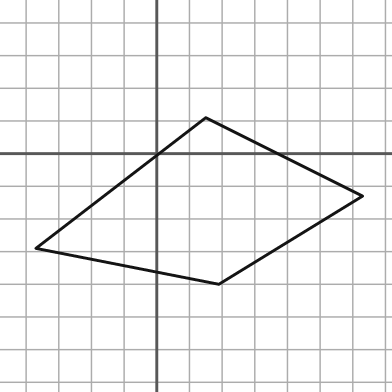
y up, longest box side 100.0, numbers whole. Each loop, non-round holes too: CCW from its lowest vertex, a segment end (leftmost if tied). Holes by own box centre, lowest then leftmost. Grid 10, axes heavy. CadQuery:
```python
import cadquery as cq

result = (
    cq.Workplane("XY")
    .moveTo(19.0, -40.0)
    .lineTo(63.0, -13.0)
    .lineTo(15.0, 11.0)
    .lineTo(-37.0, -29.0)
    .close()
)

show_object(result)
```